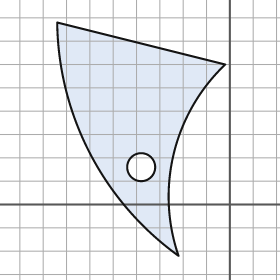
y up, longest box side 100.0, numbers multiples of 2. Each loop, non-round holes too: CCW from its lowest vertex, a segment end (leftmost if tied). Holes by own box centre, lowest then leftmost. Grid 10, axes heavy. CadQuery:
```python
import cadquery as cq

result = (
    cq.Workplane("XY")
    .moveTo(-22.0, -22.0)
    .threePointArc((-24.0, 22.0), (-2.0, 60.0))
    .lineTo(-74.0, 78.0)
    .threePointArc((-60.0, 22.0), (-22.0, -22.0))
    .close()
    .moveTo(-38.0, 16.0)
    .circle(6.0)
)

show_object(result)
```